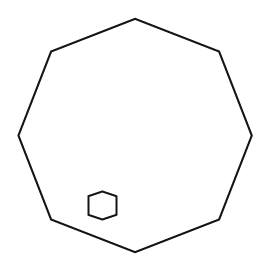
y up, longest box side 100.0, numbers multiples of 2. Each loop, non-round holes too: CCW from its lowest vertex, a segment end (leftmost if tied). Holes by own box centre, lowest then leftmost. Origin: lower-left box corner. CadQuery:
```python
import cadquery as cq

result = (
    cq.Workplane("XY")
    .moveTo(50.0, 0.0)
    .lineTo(86.0, 14.0)
    .lineTo(100.0, 50.0)
    .lineTo(86.0, 86.0)
    .lineTo(50.0, 100.0)
    .lineTo(14.0, 86.0)
    .lineTo(0.0, 50.0)
    .lineTo(14.0, 14.0)
    .close()
    .moveTo(36.0, 14.0)
    .lineTo(42.0, 16.0)
    .lineTo(42.0, 24.0)
    .lineTo(36.0, 26.0)
    .lineTo(30.0, 24.0)
    .lineTo(30.0, 16.0)
    .close()
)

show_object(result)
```